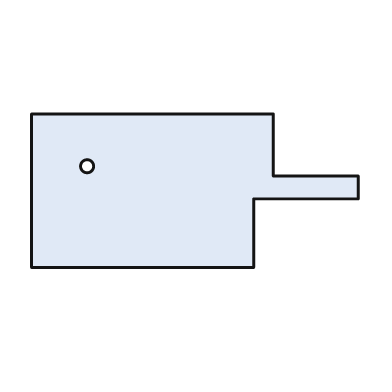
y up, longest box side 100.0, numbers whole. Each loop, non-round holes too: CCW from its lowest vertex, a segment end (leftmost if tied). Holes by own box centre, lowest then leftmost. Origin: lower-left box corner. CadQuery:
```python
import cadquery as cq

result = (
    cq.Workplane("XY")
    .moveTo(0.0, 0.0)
    .lineTo(68.0, 0.0)
    .lineTo(68.0, 21.0)
    .lineTo(100.0, 21.0)
    .lineTo(100.0, 28.0)
    .lineTo(74.0, 28.0)
    .lineTo(74.0, 47.0)
    .lineTo(0.0, 47.0)
    .close()
    .moveTo(17.0, 31.0)
    .circle(2.0)
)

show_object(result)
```